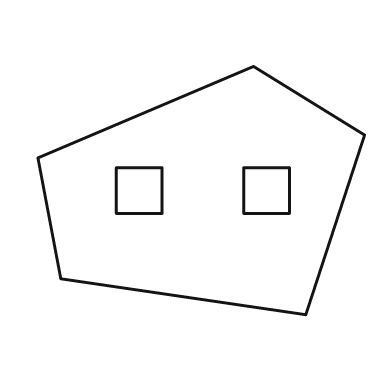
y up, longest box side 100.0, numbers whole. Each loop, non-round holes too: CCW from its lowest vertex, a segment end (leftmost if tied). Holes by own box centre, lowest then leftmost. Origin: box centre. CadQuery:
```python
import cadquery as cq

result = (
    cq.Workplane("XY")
    .moveTo(32.0, -38.0)
    .lineTo(50.0, 17.0)
    .lineTo(16.0, 38.0)
    .lineTo(-50.0, 10.0)
    .lineTo(-43.0, -27.0)
    .close()
    .moveTo(-26.0, -7.0)
    .lineTo(-12.0, -7.0)
    .lineTo(-12.0, 7.0)
    .lineTo(-26.0, 7.0)
    .close()
    .moveTo(13.0, -7.0)
    .lineTo(27.0, -7.0)
    .lineTo(27.0, 7.0)
    .lineTo(13.0, 7.0)
    .close()
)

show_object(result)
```